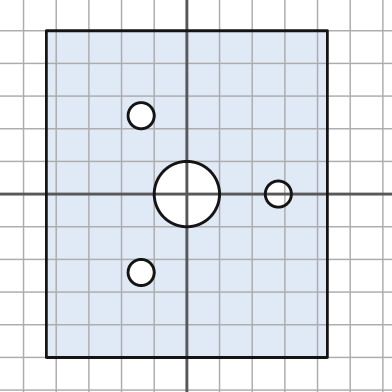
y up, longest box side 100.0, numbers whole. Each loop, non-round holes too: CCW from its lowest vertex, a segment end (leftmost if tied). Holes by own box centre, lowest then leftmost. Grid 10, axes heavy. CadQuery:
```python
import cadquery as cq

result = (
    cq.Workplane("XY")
    .moveTo(-43.0, -50.0)
    .lineTo(43.0, -50.0)
    .lineTo(43.0, 50.0)
    .lineTo(-43.0, 50.0)
    .close()
    .moveTo(-14.0, -24.0)
    .circle(4.0)
    .moveTo(0.0, 0.0)
    .circle(10.0)
    .moveTo(28.0, 0.0)
    .circle(4.0)
    .moveTo(-14.0, 24.0)
    .circle(4.0)
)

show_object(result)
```